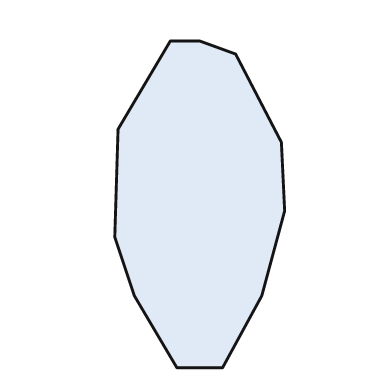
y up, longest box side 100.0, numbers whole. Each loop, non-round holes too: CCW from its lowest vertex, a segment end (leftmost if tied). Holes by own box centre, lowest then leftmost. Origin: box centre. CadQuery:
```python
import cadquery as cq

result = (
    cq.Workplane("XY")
    .moveTo(-7.0, -50.0)
    .lineTo(7.0, -50.0)
    .lineTo(19.0, -28.0)
    .lineTo(26.0, -2.0)
    .lineTo(25.0, 19.0)
    .lineTo(11.0, 46.0)
    .lineTo(0.0, 50.0)
    .lineTo(-9.0, 50.0)
    .lineTo(-25.0, 23.0)
    .lineTo(-26.0, -10.0)
    .lineTo(-20.0, -28.0)
    .close()
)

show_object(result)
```